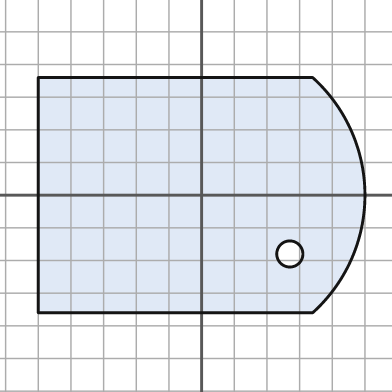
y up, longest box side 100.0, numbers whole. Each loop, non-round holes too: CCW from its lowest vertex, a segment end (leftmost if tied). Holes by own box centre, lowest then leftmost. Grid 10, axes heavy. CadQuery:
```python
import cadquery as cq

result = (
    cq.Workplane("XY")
    .moveTo(-50.0, -36.0)
    .lineTo(34.0, -36.0)
    .threePointArc((50.0, 0.0), (34.0, 36.0))
    .lineTo(-50.0, 36.0)
    .close()
    .moveTo(27.0, -18.0)
    .circle(4.0)
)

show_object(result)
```